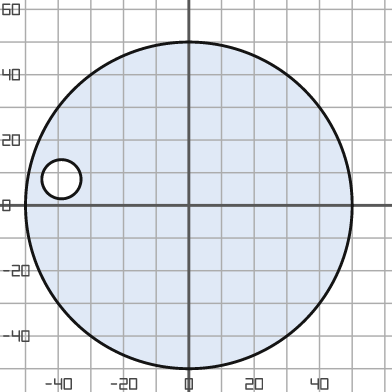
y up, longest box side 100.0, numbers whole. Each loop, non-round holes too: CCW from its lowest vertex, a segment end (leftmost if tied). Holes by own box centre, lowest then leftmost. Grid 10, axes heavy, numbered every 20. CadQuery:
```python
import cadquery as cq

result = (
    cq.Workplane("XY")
    .moveTo(0.0, 0.0)
    .circle(50.0)
    .moveTo(-39.0, 8.0)
    .circle(6.0)
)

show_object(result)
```